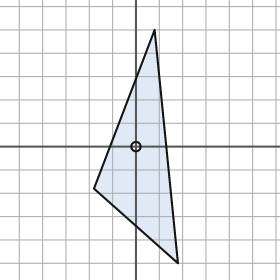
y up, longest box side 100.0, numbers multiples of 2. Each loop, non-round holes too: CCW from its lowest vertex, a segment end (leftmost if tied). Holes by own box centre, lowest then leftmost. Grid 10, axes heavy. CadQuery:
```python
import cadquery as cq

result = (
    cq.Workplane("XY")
    .moveTo(18.0, -50.0)
    .lineTo(8.0, 50.0)
    .lineTo(-18.0, -18.0)
    .close()
    .moveTo(0.0, 0.0)
    .circle(2.0)
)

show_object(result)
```